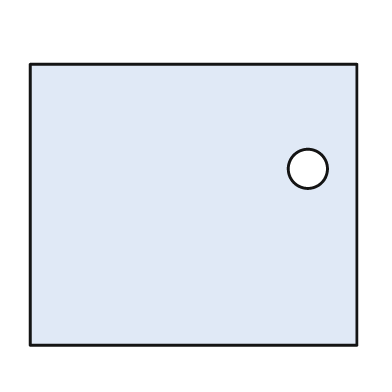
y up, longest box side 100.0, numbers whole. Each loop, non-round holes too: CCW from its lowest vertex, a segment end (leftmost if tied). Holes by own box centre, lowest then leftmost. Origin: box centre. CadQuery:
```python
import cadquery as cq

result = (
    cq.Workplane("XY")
    .moveTo(-50.0, -43.0)
    .lineTo(50.0, -43.0)
    .lineTo(50.0, 43.0)
    .lineTo(-50.0, 43.0)
    .close()
    .moveTo(35.0, 11.0)
    .circle(6.0)
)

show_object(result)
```